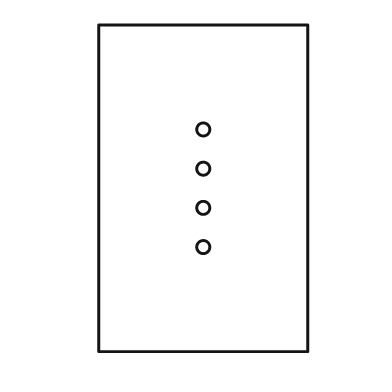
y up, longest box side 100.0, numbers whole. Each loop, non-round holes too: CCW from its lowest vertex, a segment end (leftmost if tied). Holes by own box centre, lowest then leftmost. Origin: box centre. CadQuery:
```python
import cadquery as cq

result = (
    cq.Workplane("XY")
    .moveTo(-32.0, -50.0)
    .lineTo(32.0, -50.0)
    .lineTo(32.0, 50.0)
    .lineTo(-32.0, 50.0)
    .close()
    .moveTo(0.0, -18.0)
    .circle(2.0)
    .moveTo(0.0, -6.0)
    .circle(2.0)
    .moveTo(0.0, 6.0)
    .circle(2.0)
    .moveTo(0.0, 18.0)
    .circle(2.0)
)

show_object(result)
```